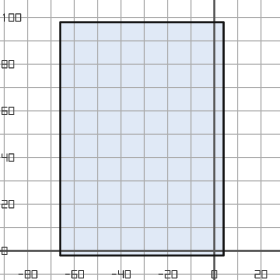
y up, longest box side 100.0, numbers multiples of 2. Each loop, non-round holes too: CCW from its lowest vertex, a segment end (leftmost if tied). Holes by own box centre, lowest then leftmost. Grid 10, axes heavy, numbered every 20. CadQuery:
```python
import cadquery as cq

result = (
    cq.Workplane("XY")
    .moveTo(-66.0, -2.0)
    .lineTo(4.0, -2.0)
    .lineTo(4.0, 98.0)
    .lineTo(-66.0, 98.0)
    .close()
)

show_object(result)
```